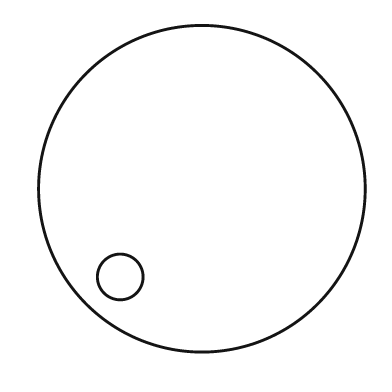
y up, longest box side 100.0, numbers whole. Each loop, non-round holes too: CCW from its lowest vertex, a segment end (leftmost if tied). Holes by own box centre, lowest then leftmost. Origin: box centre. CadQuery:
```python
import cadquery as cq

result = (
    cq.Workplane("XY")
    .moveTo(0.0, 0.0)
    .circle(50.0)
    .moveTo(-25.0, -27.0)
    .circle(7.0)
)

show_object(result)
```